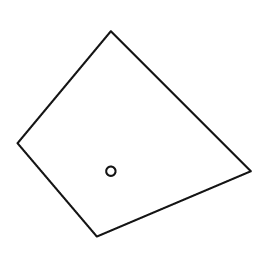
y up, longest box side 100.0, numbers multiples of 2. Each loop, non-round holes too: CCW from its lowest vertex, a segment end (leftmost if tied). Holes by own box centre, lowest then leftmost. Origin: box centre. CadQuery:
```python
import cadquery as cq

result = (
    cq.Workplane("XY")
    .moveTo(-16.0, -44.0)
    .lineTo(50.0, -16.0)
    .lineTo(-10.0, 44.0)
    .lineTo(-50.0, -4.0)
    .close()
    .moveTo(-10.0, -16.0)
    .circle(2.0)
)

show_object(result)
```